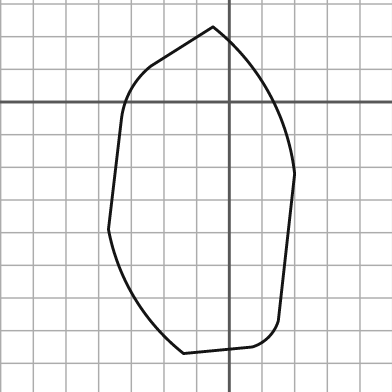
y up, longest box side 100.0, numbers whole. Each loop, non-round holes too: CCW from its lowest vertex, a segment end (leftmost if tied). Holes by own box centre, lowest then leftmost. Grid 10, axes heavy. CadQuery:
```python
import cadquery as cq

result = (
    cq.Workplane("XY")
    .moveTo(-14.0, -77.0)
    .lineTo(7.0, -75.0)
    .threePointArc((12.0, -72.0), (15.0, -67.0))
    .lineTo(20.0, -22.0)
    .threePointArc((12.0, 3.0), (-5.0, 23.0))
    .lineTo(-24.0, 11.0)
    .threePointArc((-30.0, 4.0), (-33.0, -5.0))
    .lineTo(-37.0, -39.0)
    .threePointArc((-29.0, -60.0), (-14.0, -77.0))
    .close()
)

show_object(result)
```